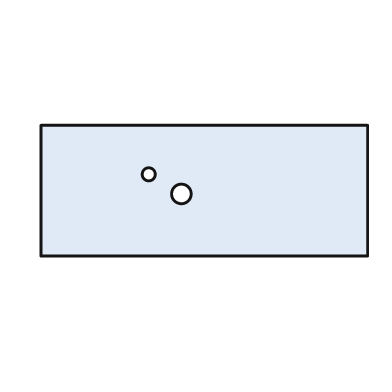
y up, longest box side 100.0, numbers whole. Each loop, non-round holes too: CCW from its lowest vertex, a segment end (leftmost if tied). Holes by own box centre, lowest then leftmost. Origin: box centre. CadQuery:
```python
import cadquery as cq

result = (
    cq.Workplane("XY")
    .moveTo(-50.0, -20.0)
    .lineTo(50.0, -20.0)
    .lineTo(50.0, 20.0)
    .lineTo(-50.0, 20.0)
    .close()
    .moveTo(-7.0, -1.0)
    .circle(3.0)
    .moveTo(-17.0, 5.0)
    .circle(2.0)
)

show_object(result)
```